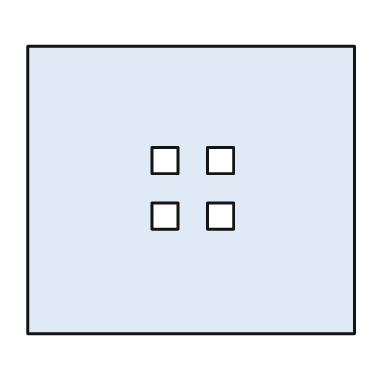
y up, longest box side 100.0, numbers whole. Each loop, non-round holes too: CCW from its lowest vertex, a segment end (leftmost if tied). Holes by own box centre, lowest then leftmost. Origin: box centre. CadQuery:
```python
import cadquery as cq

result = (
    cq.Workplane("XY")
    .moveTo(-50.0, -44.0)
    .lineTo(50.0, -44.0)
    .lineTo(50.0, 44.0)
    .lineTo(-50.0, 44.0)
    .close()
    .moveTo(-12.0, -12.0)
    .lineTo(-4.0, -12.0)
    .lineTo(-4.0, -4.0)
    .lineTo(-12.0, -4.0)
    .close()
    .moveTo(5.0, -12.0)
    .lineTo(13.0, -12.0)
    .lineTo(13.0, -4.0)
    .lineTo(5.0, -4.0)
    .close()
    .moveTo(-12.0, 5.0)
    .lineTo(-4.0, 5.0)
    .lineTo(-4.0, 13.0)
    .lineTo(-12.0, 13.0)
    .close()
    .moveTo(5.0, 5.0)
    .lineTo(13.0, 5.0)
    .lineTo(13.0, 13.0)
    .lineTo(5.0, 13.0)
    .close()
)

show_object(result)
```